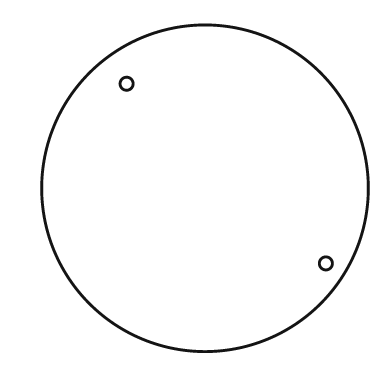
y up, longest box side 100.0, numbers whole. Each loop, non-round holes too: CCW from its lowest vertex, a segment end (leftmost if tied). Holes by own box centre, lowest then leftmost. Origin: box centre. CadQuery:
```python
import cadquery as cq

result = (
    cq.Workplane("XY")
    .moveTo(0.0, 0.0)
    .circle(50.0)
    .moveTo(37.0, -23.0)
    .circle(2.0)
    .moveTo(-24.0, 32.0)
    .circle(2.0)
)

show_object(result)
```